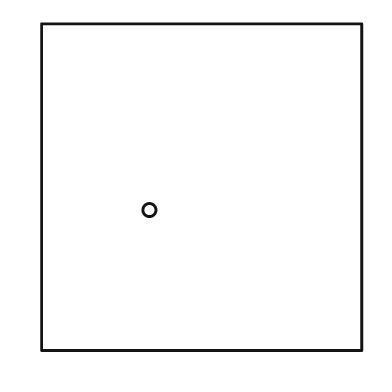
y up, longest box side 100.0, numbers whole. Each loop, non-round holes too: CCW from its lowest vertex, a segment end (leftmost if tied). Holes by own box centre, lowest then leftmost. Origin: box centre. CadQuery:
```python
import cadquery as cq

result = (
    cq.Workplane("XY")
    .moveTo(-49.0, -50.0)
    .lineTo(49.0, -50.0)
    .lineTo(49.0, 50.0)
    .lineTo(-49.0, 50.0)
    .close()
    .moveTo(-16.0, -7.0)
    .circle(2.0)
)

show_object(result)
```